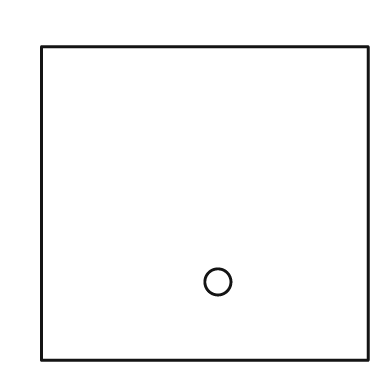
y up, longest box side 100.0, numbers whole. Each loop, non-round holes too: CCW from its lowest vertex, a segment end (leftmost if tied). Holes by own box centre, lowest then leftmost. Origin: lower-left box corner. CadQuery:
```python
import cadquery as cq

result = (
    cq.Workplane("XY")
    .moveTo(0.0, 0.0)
    .lineTo(100.0, 0.0)
    .lineTo(100.0, 96.0)
    .lineTo(0.0, 96.0)
    .close()
    .moveTo(54.0, 24.0)
    .circle(4.0)
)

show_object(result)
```